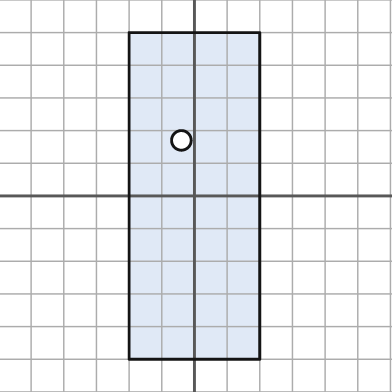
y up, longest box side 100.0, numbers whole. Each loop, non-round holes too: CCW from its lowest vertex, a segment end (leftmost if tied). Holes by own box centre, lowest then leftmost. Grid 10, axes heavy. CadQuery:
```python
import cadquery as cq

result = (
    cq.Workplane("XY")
    .moveTo(-20.0, -50.0)
    .lineTo(20.0, -50.0)
    .lineTo(20.0, 50.0)
    .lineTo(-20.0, 50.0)
    .close()
    .moveTo(-4.0, 17.0)
    .circle(3.0)
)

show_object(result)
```